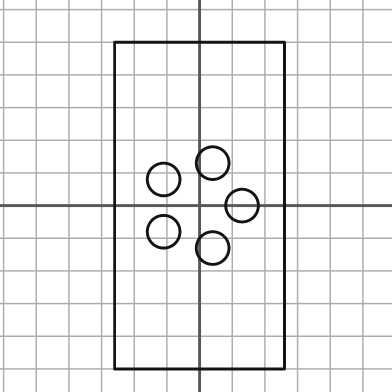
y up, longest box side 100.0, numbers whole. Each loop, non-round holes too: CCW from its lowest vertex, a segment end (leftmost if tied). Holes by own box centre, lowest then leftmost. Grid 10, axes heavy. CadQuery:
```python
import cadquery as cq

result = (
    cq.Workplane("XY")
    .moveTo(-26.0, -50.0)
    .lineTo(26.0, -50.0)
    .lineTo(26.0, 50.0)
    .lineTo(-26.0, 50.0)
    .close()
    .moveTo(4.0, -13.0)
    .circle(5.0)
    .moveTo(-11.0, -8.0)
    .circle(5.0)
    .moveTo(13.0, 0.0)
    .circle(5.0)
    .moveTo(-11.0, 8.0)
    .circle(5.0)
    .moveTo(4.0, 13.0)
    .circle(5.0)
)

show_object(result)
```